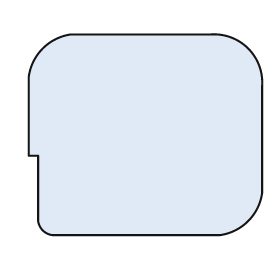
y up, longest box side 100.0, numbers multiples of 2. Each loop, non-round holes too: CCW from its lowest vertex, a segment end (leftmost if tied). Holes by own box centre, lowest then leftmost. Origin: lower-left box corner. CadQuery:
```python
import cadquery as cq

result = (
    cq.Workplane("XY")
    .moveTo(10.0, 0.0)
    .lineTo(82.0, 0.0)
    .threePointArc((94.0, 6.0), (100.0, 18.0))
    .lineTo(100.0, 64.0)
    .threePointArc((94.0, 80.0), (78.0, 86.0))
    .lineTo(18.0, 86.0)
    .threePointArc((6.0, 80.0), (0.0, 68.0))
    .lineTo(0.0, 34.0)
    .lineTo(4.0, 34.0)
    .lineTo(4.0, 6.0)
    .threePointArc((6.0, 2.0), (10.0, 0.0))
    .close()
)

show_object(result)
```